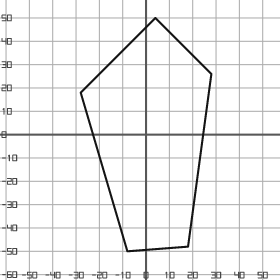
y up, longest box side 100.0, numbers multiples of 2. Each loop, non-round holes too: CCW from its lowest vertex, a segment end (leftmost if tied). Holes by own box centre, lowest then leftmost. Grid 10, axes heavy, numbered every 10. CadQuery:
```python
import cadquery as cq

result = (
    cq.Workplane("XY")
    .moveTo(-8.0, -50.0)
    .lineTo(18.0, -48.0)
    .lineTo(28.0, 26.0)
    .lineTo(4.0, 50.0)
    .lineTo(-28.0, 18.0)
    .close()
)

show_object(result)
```